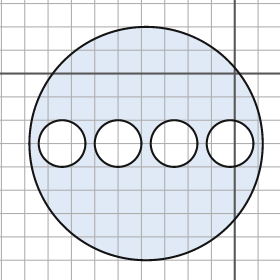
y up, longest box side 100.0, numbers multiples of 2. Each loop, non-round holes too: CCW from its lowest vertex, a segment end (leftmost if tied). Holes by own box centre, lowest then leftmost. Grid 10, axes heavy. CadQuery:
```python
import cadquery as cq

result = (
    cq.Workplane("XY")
    .moveTo(-38.0, -30.0)
    .circle(50.0)
    .moveTo(-74.0, -30.0)
    .circle(10.0)
    .moveTo(-50.0, -30.0)
    .circle(10.0)
    .moveTo(-26.0, -30.0)
    .circle(10.0)
    .moveTo(-2.0, -30.0)
    .circle(10.0)
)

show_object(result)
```